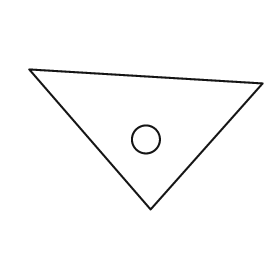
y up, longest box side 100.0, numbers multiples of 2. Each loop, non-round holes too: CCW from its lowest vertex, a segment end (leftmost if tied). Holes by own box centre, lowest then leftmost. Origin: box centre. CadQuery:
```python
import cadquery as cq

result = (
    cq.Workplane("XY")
    .moveTo(2.0, -30.0)
    .lineTo(50.0, 24.0)
    .lineTo(-50.0, 30.0)
    .close()
    .moveTo(0.0, 0.0)
    .circle(6.0)
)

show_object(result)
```